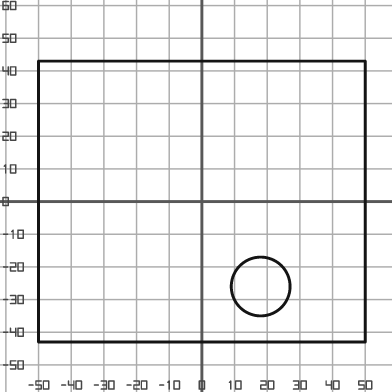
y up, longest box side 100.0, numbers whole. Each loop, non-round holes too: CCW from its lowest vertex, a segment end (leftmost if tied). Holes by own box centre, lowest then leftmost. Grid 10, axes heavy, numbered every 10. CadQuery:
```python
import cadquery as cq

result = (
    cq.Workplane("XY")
    .moveTo(-50.0, -43.0)
    .lineTo(50.0, -43.0)
    .lineTo(50.0, 43.0)
    .lineTo(-50.0, 43.0)
    .close()
    .moveTo(18.0, -26.0)
    .circle(9.0)
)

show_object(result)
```